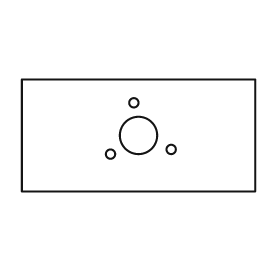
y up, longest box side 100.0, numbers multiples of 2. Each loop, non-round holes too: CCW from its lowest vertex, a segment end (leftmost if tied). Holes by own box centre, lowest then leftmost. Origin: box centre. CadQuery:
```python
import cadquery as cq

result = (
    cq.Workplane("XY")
    .moveTo(-50.0, -24.0)
    .lineTo(50.0, -24.0)
    .lineTo(50.0, 24.0)
    .lineTo(-50.0, 24.0)
    .close()
    .moveTo(-12.0, -8.0)
    .circle(2.0)
    .moveTo(14.0, -6.0)
    .circle(2.0)
    .moveTo(0.0, 0.0)
    .circle(8.0)
    .moveTo(-2.0, 14.0)
    .circle(2.0)
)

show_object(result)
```